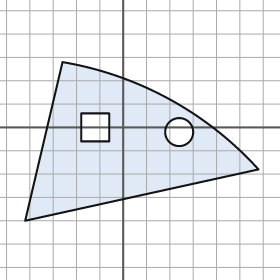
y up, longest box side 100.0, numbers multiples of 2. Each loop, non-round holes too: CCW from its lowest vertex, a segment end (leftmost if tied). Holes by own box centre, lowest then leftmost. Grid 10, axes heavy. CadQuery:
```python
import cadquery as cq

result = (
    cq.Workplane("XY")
    .moveTo(-42.0, -40.0)
    .lineTo(58.0, -18.0)
    .threePointArc((20.0, 12.0), (-26.0, 28.0))
    .close()
    .moveTo(24.0, -2.0)
    .circle(6.0)
    .moveTo(-18.0, -6.0)
    .lineTo(-6.0, -6.0)
    .lineTo(-6.0, 6.0)
    .lineTo(-18.0, 6.0)
    .close()
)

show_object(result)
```